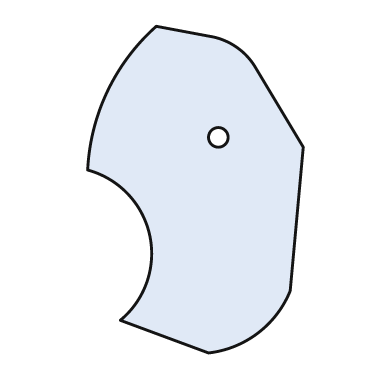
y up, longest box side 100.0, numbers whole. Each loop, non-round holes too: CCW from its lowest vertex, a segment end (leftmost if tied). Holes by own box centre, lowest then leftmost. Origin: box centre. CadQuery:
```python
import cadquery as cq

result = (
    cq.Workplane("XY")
    .moveTo(4.0, -50.0)
    .threePointArc((19.0, -44.0), (29.0, -31.0))
    .lineTo(33.0, 13.0)
    .lineTo(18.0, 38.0)
    .threePointArc((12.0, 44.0), (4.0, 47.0))
    .lineTo(-12.0, 50.0)
    .threePointArc((-27.0, 30.0), (-33.0, 6.0))
    .threePointArc((-14.0, -14.0), (-23.0, -40.0))
    .close()
    .moveTo(7.0, 16.0)
    .circle(3.0)
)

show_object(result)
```